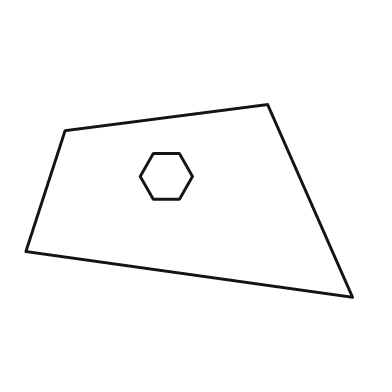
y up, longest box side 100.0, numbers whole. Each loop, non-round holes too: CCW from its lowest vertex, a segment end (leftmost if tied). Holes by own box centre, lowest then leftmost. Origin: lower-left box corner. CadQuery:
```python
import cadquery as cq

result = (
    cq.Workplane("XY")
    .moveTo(100.0, 0.0)
    .lineTo(74.0, 59.0)
    .lineTo(12.0, 51.0)
    .lineTo(0.0, 14.0)
    .close()
    .moveTo(39.0, 30.0)
    .lineTo(47.0, 30.0)
    .lineTo(51.0, 37.0)
    .lineTo(47.0, 44.0)
    .lineTo(39.0, 44.0)
    .lineTo(35.0, 37.0)
    .close()
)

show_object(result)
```